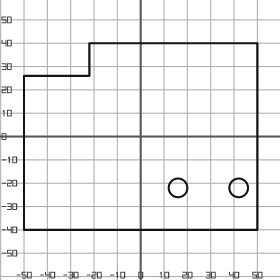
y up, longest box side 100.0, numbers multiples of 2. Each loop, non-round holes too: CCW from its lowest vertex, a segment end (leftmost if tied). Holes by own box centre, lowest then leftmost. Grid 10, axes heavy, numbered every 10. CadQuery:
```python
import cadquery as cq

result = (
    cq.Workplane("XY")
    .moveTo(-50.0, -40.0)
    .lineTo(50.0, -40.0)
    .lineTo(50.0, 40.0)
    .lineTo(-22.0, 40.0)
    .lineTo(-22.0, 26.0)
    .lineTo(-50.0, 26.0)
    .close()
    .moveTo(16.0, -22.0)
    .circle(4.0)
    .moveTo(42.0, -22.0)
    .circle(4.0)
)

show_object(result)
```